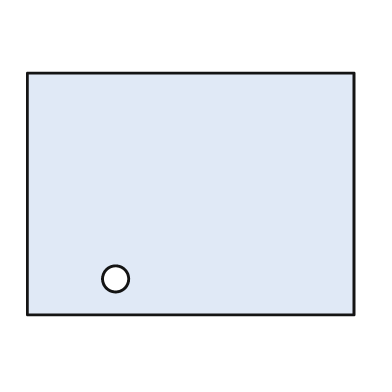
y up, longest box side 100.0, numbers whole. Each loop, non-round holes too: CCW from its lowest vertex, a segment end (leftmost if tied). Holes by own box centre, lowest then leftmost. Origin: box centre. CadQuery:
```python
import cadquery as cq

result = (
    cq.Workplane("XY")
    .moveTo(-50.0, -37.0)
    .lineTo(50.0, -37.0)
    .lineTo(50.0, 37.0)
    .lineTo(-50.0, 37.0)
    .close()
    .moveTo(-23.0, -26.0)
    .circle(4.0)
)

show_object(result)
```